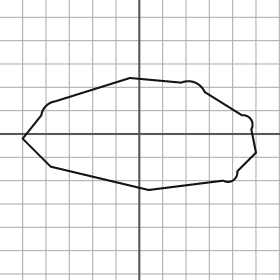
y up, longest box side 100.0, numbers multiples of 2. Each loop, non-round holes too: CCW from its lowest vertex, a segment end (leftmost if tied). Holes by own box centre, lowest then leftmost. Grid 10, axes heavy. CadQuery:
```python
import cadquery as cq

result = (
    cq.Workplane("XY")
    .moveTo(4.0, -24.0)
    .lineTo(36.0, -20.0)
    .threePointArc((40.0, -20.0), (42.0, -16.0))
    .lineTo(50.0, -8.0)
    .lineTo(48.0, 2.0)
    .threePointArc((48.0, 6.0), (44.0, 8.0))
    .lineTo(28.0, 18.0)
    .threePointArc((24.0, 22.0), (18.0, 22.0))
    .lineTo(-4.0, 24.0)
    .lineTo(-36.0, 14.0)
    .threePointArc((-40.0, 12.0), (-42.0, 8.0))
    .lineTo(-50.0, -2.0)
    .lineTo(-38.0, -14.0)
    .close()
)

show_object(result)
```